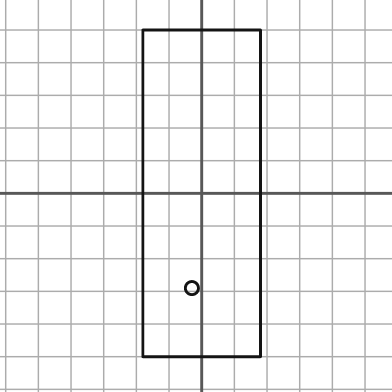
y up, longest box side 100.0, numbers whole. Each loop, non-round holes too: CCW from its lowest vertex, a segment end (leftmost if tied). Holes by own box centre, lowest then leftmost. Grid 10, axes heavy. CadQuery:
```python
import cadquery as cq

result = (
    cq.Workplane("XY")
    .moveTo(-18.0, -50.0)
    .lineTo(18.0, -50.0)
    .lineTo(18.0, 50.0)
    .lineTo(-18.0, 50.0)
    .close()
    .moveTo(-3.0, -29.0)
    .circle(2.0)
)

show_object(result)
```